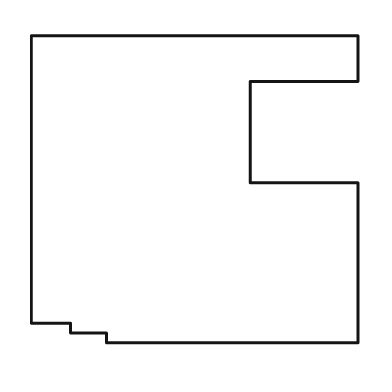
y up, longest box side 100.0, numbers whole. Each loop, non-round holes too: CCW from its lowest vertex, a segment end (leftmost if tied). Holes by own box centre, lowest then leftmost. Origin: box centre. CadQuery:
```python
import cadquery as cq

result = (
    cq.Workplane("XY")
    .moveTo(-27.0, -47.0)
    .lineTo(50.0, -47.0)
    .lineTo(50.0, 2.0)
    .lineTo(17.0, 2.0)
    .lineTo(17.0, 33.0)
    .lineTo(50.0, 33.0)
    .lineTo(50.0, 47.0)
    .lineTo(-50.0, 47.0)
    .lineTo(-50.0, -41.0)
    .lineTo(-38.0, -41.0)
    .lineTo(-38.0, -44.0)
    .lineTo(-27.0, -44.0)
    .close()
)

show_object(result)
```